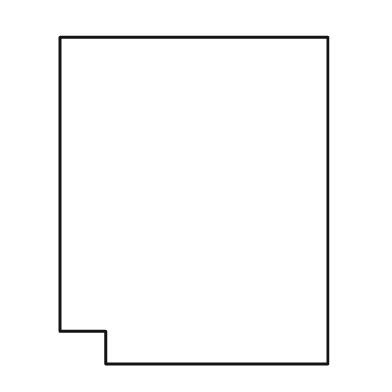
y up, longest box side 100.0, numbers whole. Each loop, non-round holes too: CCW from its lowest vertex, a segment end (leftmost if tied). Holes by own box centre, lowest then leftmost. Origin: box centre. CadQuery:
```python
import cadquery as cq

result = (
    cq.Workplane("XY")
    .moveTo(-27.0, -50.0)
    .lineTo(41.0, -50.0)
    .lineTo(41.0, 50.0)
    .lineTo(-41.0, 50.0)
    .lineTo(-41.0, -40.0)
    .lineTo(-27.0, -40.0)
    .close()
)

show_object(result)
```